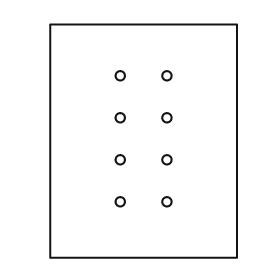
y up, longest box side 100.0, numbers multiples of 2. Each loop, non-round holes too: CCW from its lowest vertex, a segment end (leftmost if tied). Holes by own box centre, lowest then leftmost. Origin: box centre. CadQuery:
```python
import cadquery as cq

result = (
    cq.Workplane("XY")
    .moveTo(-40.0, -50.0)
    .lineTo(40.0, -50.0)
    .lineTo(40.0, 50.0)
    .lineTo(-40.0, 50.0)
    .close()
    .moveTo(-10.0, -26.0)
    .circle(2.0)
    .moveTo(10.0, -26.0)
    .circle(2.0)
    .moveTo(-10.0, -8.0)
    .circle(2.0)
    .moveTo(10.0, -8.0)
    .circle(2.0)
    .moveTo(-10.0, 10.0)
    .circle(2.0)
    .moveTo(10.0, 10.0)
    .circle(2.0)
    .moveTo(-10.0, 28.0)
    .circle(2.0)
    .moveTo(10.0, 28.0)
    .circle(2.0)
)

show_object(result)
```